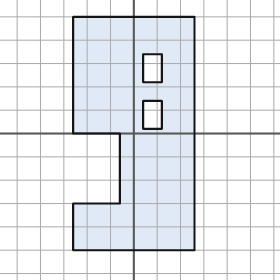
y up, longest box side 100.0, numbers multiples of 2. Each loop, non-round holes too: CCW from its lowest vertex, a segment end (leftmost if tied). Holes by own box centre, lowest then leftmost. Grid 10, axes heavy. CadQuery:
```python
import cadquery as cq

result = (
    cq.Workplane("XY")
    .moveTo(-26.0, -50.0)
    .lineTo(26.0, -50.0)
    .lineTo(26.0, 50.0)
    .lineTo(-26.0, 50.0)
    .lineTo(-26.0, 0.0)
    .lineTo(-6.0, 0.0)
    .lineTo(-6.0, -30.0)
    .lineTo(-26.0, -30.0)
    .close()
    .moveTo(4.0, 2.0)
    .lineTo(12.0, 2.0)
    .lineTo(12.0, 14.0)
    .lineTo(4.0, 14.0)
    .close()
    .moveTo(4.0, 22.0)
    .lineTo(12.0, 22.0)
    .lineTo(12.0, 34.0)
    .lineTo(4.0, 34.0)
    .close()
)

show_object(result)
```